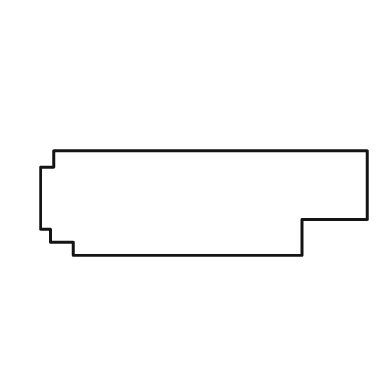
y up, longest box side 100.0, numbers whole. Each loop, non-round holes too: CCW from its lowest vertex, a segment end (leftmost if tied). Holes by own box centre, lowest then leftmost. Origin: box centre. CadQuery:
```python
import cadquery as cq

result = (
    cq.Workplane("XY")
    .moveTo(-40.0, -16.0)
    .lineTo(30.0, -16.0)
    .lineTo(30.0, -5.0)
    .lineTo(50.0, -5.0)
    .lineTo(50.0, 16.0)
    .lineTo(-46.0, 16.0)
    .lineTo(-46.0, 11.0)
    .lineTo(-50.0, 11.0)
    .lineTo(-50.0, -8.0)
    .lineTo(-47.0, -8.0)
    .lineTo(-47.0, -12.0)
    .lineTo(-40.0, -12.0)
    .close()
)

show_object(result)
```